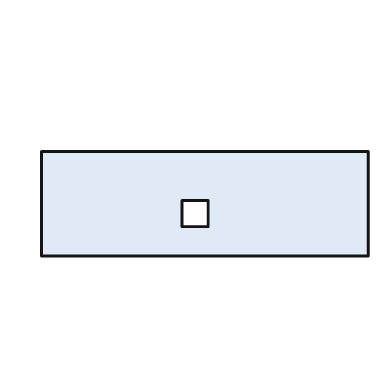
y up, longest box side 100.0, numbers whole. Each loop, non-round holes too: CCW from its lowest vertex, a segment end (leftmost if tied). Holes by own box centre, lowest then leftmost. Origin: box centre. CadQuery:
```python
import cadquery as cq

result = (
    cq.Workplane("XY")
    .moveTo(-50.0, -16.0)
    .lineTo(50.0, -16.0)
    .lineTo(50.0, 16.0)
    .lineTo(-50.0, 16.0)
    .close()
    .moveTo(-7.0, -7.0)
    .lineTo(1.0, -7.0)
    .lineTo(1.0, 1.0)
    .lineTo(-7.0, 1.0)
    .close()
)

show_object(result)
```